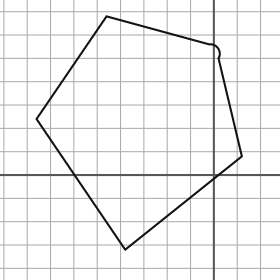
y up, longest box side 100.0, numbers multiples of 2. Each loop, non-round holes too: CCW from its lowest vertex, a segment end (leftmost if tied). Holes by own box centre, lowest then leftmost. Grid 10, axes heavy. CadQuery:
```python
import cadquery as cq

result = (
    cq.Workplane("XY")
    .moveTo(-38.0, -32.0)
    .lineTo(12.0, 8.0)
    .lineTo(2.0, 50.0)
    .threePointArc((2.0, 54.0), (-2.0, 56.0))
    .lineTo(-46.0, 68.0)
    .lineTo(-76.0, 24.0)
    .close()
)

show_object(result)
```